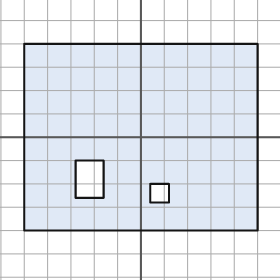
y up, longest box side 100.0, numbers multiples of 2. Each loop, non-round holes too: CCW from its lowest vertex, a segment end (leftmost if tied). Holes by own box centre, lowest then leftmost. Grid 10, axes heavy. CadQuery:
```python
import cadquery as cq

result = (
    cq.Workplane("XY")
    .moveTo(-50.0, -40.0)
    .lineTo(50.0, -40.0)
    .lineTo(50.0, 40.0)
    .lineTo(-50.0, 40.0)
    .close()
    .moveTo(4.0, -28.0)
    .lineTo(12.0, -28.0)
    .lineTo(12.0, -20.0)
    .lineTo(4.0, -20.0)
    .close()
    .moveTo(-28.0, -26.0)
    .lineTo(-16.0, -26.0)
    .lineTo(-16.0, -10.0)
    .lineTo(-28.0, -10.0)
    .close()
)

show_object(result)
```